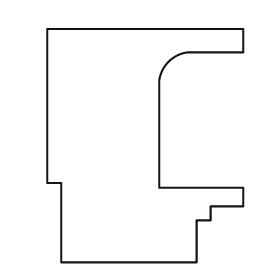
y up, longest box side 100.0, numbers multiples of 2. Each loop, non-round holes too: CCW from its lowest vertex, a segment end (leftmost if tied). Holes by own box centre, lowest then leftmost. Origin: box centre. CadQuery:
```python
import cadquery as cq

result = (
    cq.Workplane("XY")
    .moveTo(-36.0, -50.0)
    .lineTo(22.0, -50.0)
    .lineTo(22.0, -32.0)
    .lineTo(28.0, -32.0)
    .lineTo(28.0, -26.0)
    .lineTo(42.0, -26.0)
    .lineTo(42.0, -18.0)
    .lineTo(6.0, -18.0)
    .lineTo(6.0, 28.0)
    .threePointArc((10.0, 36.0), (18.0, 40.0))
    .lineTo(42.0, 40.0)
    .lineTo(42.0, 50.0)
    .lineTo(-42.0, 50.0)
    .lineTo(-42.0, -16.0)
    .lineTo(-36.0, -16.0)
    .close()
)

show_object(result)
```